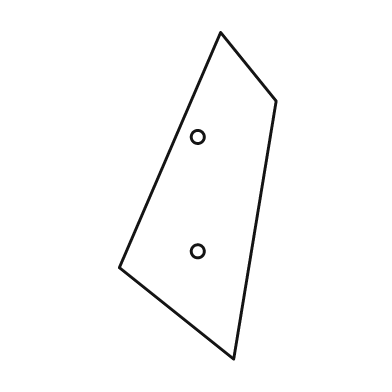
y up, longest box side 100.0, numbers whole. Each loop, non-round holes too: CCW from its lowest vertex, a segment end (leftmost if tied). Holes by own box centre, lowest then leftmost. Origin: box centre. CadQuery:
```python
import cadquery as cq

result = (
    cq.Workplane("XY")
    .moveTo(11.0, -50.0)
    .lineTo(24.0, 29.0)
    .lineTo(7.0, 50.0)
    .lineTo(-24.0, -22.0)
    .close()
    .moveTo(0.0, -17.0)
    .circle(2.0)
    .moveTo(0.0, 18.0)
    .circle(2.0)
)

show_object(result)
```